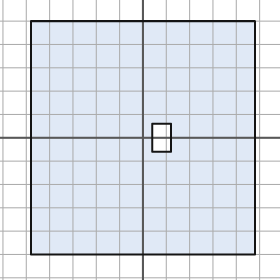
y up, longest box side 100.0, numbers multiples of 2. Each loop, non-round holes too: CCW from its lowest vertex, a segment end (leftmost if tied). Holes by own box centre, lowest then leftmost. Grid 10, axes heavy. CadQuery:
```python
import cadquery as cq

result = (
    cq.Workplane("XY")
    .moveTo(-48.0, -50.0)
    .lineTo(48.0, -50.0)
    .lineTo(48.0, 50.0)
    .lineTo(-48.0, 50.0)
    .close()
    .moveTo(4.0, -6.0)
    .lineTo(12.0, -6.0)
    .lineTo(12.0, 6.0)
    .lineTo(4.0, 6.0)
    .close()
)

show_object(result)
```